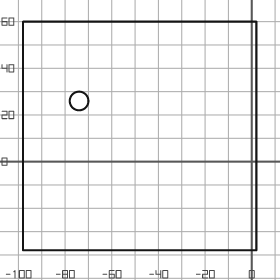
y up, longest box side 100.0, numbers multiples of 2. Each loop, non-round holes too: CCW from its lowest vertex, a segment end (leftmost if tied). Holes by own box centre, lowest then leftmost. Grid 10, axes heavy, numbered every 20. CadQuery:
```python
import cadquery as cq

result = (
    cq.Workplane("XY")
    .moveTo(-98.0, -38.0)
    .lineTo(2.0, -38.0)
    .lineTo(2.0, 60.0)
    .lineTo(-98.0, 60.0)
    .close()
    .moveTo(-74.0, 26.0)
    .circle(4.0)
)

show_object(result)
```